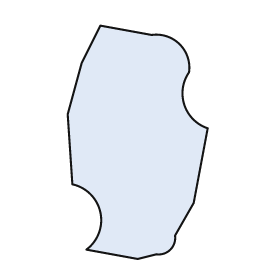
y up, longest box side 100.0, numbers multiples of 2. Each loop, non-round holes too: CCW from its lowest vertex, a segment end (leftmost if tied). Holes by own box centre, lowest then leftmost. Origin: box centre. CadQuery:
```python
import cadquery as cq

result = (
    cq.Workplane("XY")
    .moveTo(0.0, -50.0)
    .lineTo(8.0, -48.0)
    .threePointArc((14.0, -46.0), (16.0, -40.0))
    .lineTo(24.0, -26.0)
    .lineTo(30.0, 6.0)
    .threePointArc((20.0, 16.0), (22.0, 30.0))
    .threePointArc((18.0, 42.0), (6.0, 46.0))
    .lineTo(-16.0, 50.0)
    .lineTo(-24.0, 34.0)
    .lineTo(-30.0, 12.0)
    .lineTo(-28.0, -18.0)
    .threePointArc((-16.0, -30.0), (-22.0, -46.0))
    .close()
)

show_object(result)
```